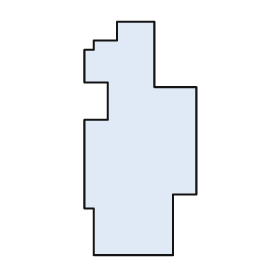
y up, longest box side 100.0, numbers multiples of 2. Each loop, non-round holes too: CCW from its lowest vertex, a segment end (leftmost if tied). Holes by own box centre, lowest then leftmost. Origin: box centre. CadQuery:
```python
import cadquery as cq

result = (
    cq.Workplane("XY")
    .moveTo(-20.0, -50.0)
    .lineTo(14.0, -50.0)
    .lineTo(14.0, -24.0)
    .lineTo(24.0, -24.0)
    .lineTo(24.0, 22.0)
    .lineTo(6.0, 22.0)
    .lineTo(6.0, 50.0)
    .lineTo(-10.0, 50.0)
    .lineTo(-10.0, 42.0)
    .lineTo(-20.0, 42.0)
    .lineTo(-20.0, 38.0)
    .lineTo(-24.0, 38.0)
    .lineTo(-24.0, 24.0)
    .lineTo(-14.0, 24.0)
    .lineTo(-14.0, 8.0)
    .lineTo(-24.0, 8.0)
    .lineTo(-24.0, -30.0)
    .lineTo(-20.0, -30.0)
    .close()
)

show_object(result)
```